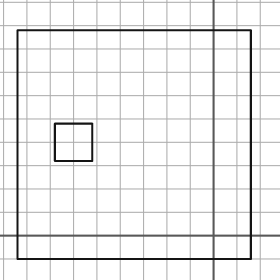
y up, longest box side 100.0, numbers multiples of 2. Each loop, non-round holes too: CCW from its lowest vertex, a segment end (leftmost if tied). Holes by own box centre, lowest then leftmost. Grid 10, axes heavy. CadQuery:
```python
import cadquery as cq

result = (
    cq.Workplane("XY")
    .moveTo(-84.0, -10.0)
    .lineTo(16.0, -10.0)
    .lineTo(16.0, 88.0)
    .lineTo(-84.0, 88.0)
    .close()
    .moveTo(-68.0, 32.0)
    .lineTo(-52.0, 32.0)
    .lineTo(-52.0, 48.0)
    .lineTo(-68.0, 48.0)
    .close()
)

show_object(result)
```